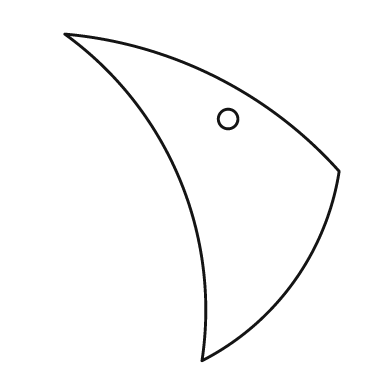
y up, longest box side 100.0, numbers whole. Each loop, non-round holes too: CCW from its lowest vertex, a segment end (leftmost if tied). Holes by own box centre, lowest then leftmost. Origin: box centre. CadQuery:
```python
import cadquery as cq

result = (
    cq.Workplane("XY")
    .moveTo(0.0, -50.0)
    .threePointArc((28.0, -26.0), (42.0, 8.0))
    .threePointArc((4.0, 37.0), (-42.0, 50.0))
    .threePointArc((-7.0, 6.0), (0.0, -50.0))
    .close()
    .moveTo(8.0, 24.0)
    .circle(3.0)
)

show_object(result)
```